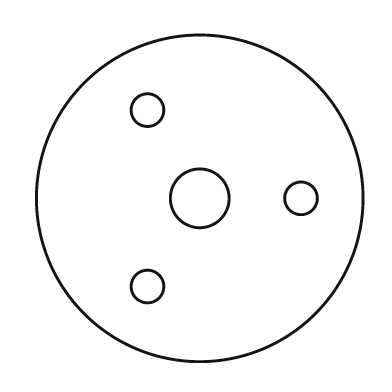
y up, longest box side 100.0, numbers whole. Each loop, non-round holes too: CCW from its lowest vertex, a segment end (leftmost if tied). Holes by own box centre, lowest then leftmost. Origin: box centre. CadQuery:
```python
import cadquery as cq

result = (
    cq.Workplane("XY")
    .moveTo(0.0, 0.0)
    .circle(50.0)
    .moveTo(-16.0, -27.0)
    .circle(5.0)
    .moveTo(0.0, 0.0)
    .circle(9.0)
    .moveTo(31.0, 0.0)
    .circle(5.0)
    .moveTo(-16.0, 27.0)
    .circle(5.0)
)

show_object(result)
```